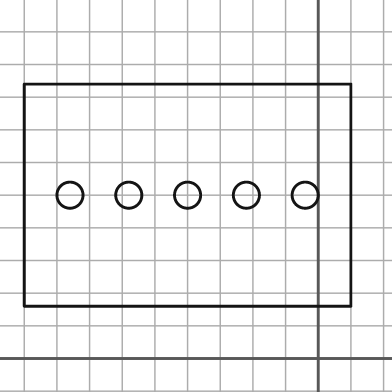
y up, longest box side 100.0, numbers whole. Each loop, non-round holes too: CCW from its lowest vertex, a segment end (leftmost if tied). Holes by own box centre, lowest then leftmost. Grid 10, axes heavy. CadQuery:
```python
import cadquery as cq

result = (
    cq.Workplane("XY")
    .moveTo(-90.0, 16.0)
    .lineTo(10.0, 16.0)
    .lineTo(10.0, 84.0)
    .lineTo(-90.0, 84.0)
    .close()
    .moveTo(-76.0, 50.0)
    .circle(4.0)
    .moveTo(-58.0, 50.0)
    .circle(4.0)
    .moveTo(-40.0, 50.0)
    .circle(4.0)
    .moveTo(-22.0, 50.0)
    .circle(4.0)
    .moveTo(-4.0, 50.0)
    .circle(4.0)
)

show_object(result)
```